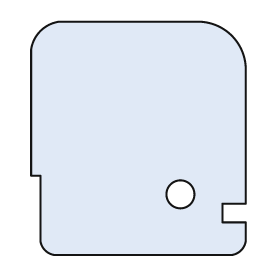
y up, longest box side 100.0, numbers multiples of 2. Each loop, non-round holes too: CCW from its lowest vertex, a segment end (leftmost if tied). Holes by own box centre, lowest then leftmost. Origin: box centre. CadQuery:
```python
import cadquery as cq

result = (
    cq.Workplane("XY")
    .moveTo(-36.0, -50.0)
    .lineTo(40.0, -50.0)
    .threePointArc((44.0, -48.0), (46.0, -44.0))
    .lineTo(46.0, -36.0)
    .lineTo(36.0, -36.0)
    .lineTo(36.0, -28.0)
    .lineTo(46.0, -28.0)
    .lineTo(46.0, 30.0)
    .threePointArc((40.0, 44.0), (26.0, 50.0))
    .lineTo(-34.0, 50.0)
    .threePointArc((-42.0, 46.0), (-46.0, 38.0))
    .lineTo(-46.0, -16.0)
    .lineTo(-42.0, -16.0)
    .lineTo(-42.0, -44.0)
    .threePointArc((-40.0, -48.0), (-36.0, -50.0))
    .close()
    .moveTo(18.0, -24.0)
    .circle(6.0)
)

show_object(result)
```